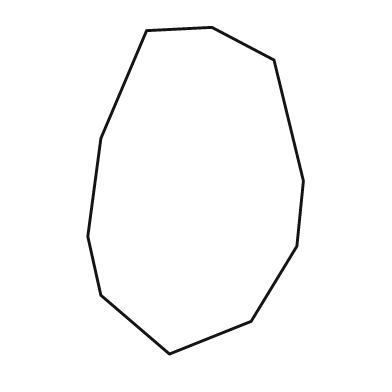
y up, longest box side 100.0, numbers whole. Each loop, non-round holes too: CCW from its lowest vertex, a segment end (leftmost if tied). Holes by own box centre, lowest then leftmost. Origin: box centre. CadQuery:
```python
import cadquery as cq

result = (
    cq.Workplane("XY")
    .moveTo(-8.0, -50.0)
    .lineTo(17.0, -40.0)
    .lineTo(31.0, -17.0)
    .lineTo(33.0, 3.0)
    .lineTo(24.0, 40.0)
    .lineTo(5.0, 50.0)
    .lineTo(-15.0, 49.0)
    .lineTo(-29.0, 16.0)
    .lineTo(-33.0, -14.0)
    .lineTo(-29.0, -32.0)
    .close()
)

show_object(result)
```